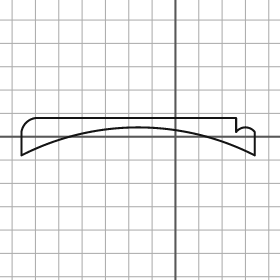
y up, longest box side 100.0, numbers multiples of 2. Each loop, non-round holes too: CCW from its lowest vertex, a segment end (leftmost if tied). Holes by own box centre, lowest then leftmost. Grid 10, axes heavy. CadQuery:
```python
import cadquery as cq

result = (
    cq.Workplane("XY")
    .moveTo(-66.0, -8.0)
    .threePointArc((-16.0, 4.0), (34.0, -8.0))
    .lineTo(34.0, 2.0)
    .threePointArc((30.0, 4.0), (26.0, 2.0))
    .lineTo(26.0, 8.0)
    .lineTo(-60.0, 8.0)
    .threePointArc((-64.0, 6.0), (-66.0, 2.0))
    .close()
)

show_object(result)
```